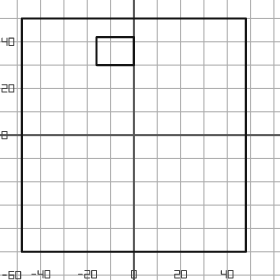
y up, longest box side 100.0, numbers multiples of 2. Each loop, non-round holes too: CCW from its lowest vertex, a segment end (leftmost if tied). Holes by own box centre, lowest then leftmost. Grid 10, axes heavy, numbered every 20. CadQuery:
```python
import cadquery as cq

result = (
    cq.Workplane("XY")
    .moveTo(-48.0, -50.0)
    .lineTo(48.0, -50.0)
    .lineTo(48.0, 50.0)
    .lineTo(-48.0, 50.0)
    .close()
    .moveTo(-16.0, 30.0)
    .lineTo(0.0, 30.0)
    .lineTo(0.0, 42.0)
    .lineTo(-16.0, 42.0)
    .close()
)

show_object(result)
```